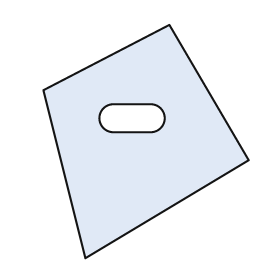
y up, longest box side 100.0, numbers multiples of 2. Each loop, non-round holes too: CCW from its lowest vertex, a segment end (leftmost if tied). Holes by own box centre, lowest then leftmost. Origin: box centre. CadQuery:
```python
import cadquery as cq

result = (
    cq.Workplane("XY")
    .moveTo(-26.0, -50.0)
    .lineTo(44.0, -8.0)
    .lineTo(10.0, 50.0)
    .lineTo(-44.0, 22.0)
    .close()
    .moveTo(-14.0, 4.0)
    .lineTo(2.0, 4.0)
    .threePointArc((8.0, 10.0), (2.0, 16.0))
    .lineTo(-14.0, 16.0)
    .threePointArc((-20.0, 10.0), (-14.0, 4.0))
    .close()
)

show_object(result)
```